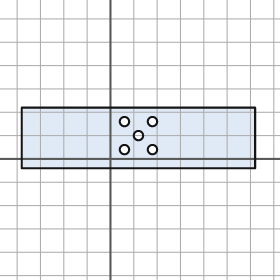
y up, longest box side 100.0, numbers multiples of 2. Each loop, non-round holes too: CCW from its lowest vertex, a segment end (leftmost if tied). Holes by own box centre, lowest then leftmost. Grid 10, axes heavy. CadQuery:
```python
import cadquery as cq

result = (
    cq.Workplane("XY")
    .moveTo(-38.0, -4.0)
    .lineTo(62.0, -4.0)
    .lineTo(62.0, 22.0)
    .lineTo(-38.0, 22.0)
    .close()
    .moveTo(6.0, 4.0)
    .circle(2.0)
    .moveTo(18.0, 4.0)
    .circle(2.0)
    .moveTo(12.0, 10.0)
    .circle(2.0)
    .moveTo(6.0, 16.0)
    .circle(2.0)
    .moveTo(18.0, 16.0)
    .circle(2.0)
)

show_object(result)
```